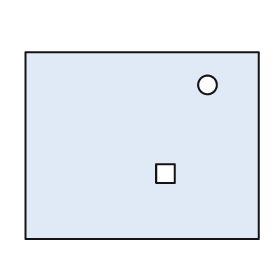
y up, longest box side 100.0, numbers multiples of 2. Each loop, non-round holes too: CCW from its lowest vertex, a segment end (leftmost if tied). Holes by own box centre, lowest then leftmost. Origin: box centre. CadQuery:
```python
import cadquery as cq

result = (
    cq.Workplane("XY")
    .moveTo(-50.0, -40.0)
    .lineTo(50.0, -40.0)
    .lineTo(50.0, 40.0)
    .lineTo(-50.0, 40.0)
    .close()
    .moveTo(6.0, -16.0)
    .lineTo(14.0, -16.0)
    .lineTo(14.0, -8.0)
    .lineTo(6.0, -8.0)
    .close()
    .moveTo(28.0, 26.0)
    .circle(4.0)
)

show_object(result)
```